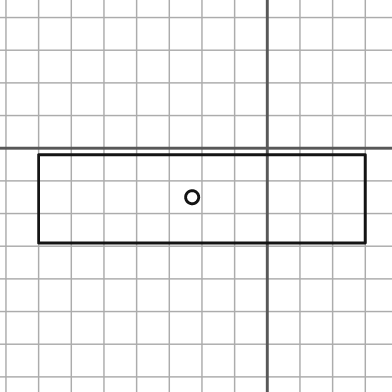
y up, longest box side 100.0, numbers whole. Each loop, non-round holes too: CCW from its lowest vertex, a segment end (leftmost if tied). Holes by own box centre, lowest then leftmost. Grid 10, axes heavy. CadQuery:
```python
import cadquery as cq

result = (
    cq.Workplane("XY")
    .moveTo(-70.0, -29.0)
    .lineTo(30.0, -29.0)
    .lineTo(30.0, -2.0)
    .lineTo(-70.0, -2.0)
    .close()
    .moveTo(-23.0, -15.0)
    .circle(2.0)
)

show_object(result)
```